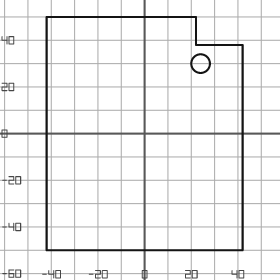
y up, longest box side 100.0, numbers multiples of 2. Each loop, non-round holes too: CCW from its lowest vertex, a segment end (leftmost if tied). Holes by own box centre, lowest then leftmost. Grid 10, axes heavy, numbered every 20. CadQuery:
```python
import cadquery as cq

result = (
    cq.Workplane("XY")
    .moveTo(-42.0, -50.0)
    .lineTo(42.0, -50.0)
    .lineTo(42.0, 38.0)
    .lineTo(22.0, 38.0)
    .lineTo(22.0, 50.0)
    .lineTo(-42.0, 50.0)
    .close()
    .moveTo(24.0, 30.0)
    .circle(4.0)
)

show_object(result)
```